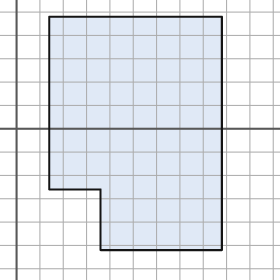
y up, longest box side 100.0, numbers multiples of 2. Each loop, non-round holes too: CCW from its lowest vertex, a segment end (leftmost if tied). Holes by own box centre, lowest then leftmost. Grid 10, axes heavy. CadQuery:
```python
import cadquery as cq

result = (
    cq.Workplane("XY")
    .moveTo(36.0, -52.0)
    .lineTo(88.0, -52.0)
    .lineTo(88.0, 48.0)
    .lineTo(14.0, 48.0)
    .lineTo(14.0, -26.0)
    .lineTo(36.0, -26.0)
    .close()
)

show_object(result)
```